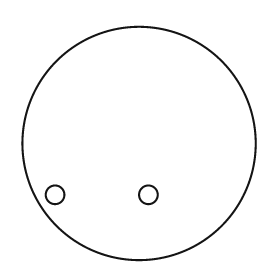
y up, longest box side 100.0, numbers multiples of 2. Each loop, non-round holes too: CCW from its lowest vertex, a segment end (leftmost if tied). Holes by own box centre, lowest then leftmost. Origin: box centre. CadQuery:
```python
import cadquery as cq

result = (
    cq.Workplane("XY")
    .moveTo(0.0, 0.0)
    .circle(50.0)
    .moveTo(-36.0, -22.0)
    .circle(4.0)
    .moveTo(4.0, -22.0)
    .circle(4.0)
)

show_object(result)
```